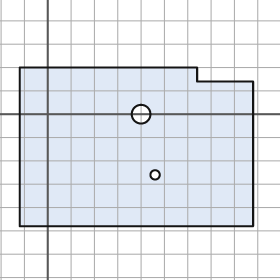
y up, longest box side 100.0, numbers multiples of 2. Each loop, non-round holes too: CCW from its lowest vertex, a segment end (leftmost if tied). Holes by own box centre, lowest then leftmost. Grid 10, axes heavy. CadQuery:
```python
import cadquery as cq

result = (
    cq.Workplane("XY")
    .moveTo(-12.0, -48.0)
    .lineTo(88.0, -48.0)
    .lineTo(88.0, 14.0)
    .lineTo(64.0, 14.0)
    .lineTo(64.0, 20.0)
    .lineTo(-12.0, 20.0)
    .close()
    .moveTo(46.0, -26.0)
    .circle(2.0)
    .moveTo(40.0, 0.0)
    .circle(4.0)
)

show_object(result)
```